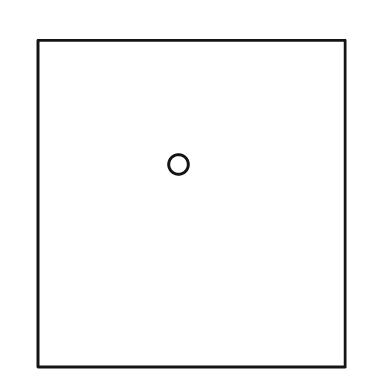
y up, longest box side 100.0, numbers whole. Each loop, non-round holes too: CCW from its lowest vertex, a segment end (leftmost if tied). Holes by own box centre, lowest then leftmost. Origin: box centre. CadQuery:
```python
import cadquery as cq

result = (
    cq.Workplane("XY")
    .moveTo(-47.0, -50.0)
    .lineTo(47.0, -50.0)
    .lineTo(47.0, 50.0)
    .lineTo(-47.0, 50.0)
    .close()
    .moveTo(-4.0, 12.0)
    .circle(3.0)
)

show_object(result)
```